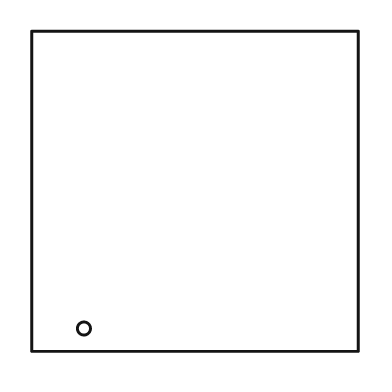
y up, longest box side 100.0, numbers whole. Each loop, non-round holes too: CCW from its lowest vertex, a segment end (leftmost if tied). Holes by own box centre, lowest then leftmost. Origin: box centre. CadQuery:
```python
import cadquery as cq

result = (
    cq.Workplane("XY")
    .moveTo(-50.0, -49.0)
    .lineTo(50.0, -49.0)
    .lineTo(50.0, 49.0)
    .lineTo(-50.0, 49.0)
    .close()
    .moveTo(-34.0, -42.0)
    .circle(2.0)
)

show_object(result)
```